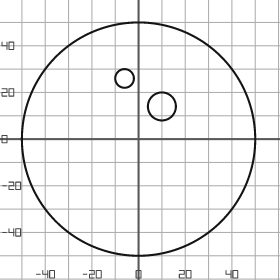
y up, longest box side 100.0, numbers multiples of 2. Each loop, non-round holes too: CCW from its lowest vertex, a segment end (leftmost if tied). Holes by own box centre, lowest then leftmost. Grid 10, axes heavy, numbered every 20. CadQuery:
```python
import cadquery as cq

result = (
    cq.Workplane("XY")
    .moveTo(0.0, 0.0)
    .circle(50.0)
    .moveTo(10.0, 14.0)
    .circle(6.0)
    .moveTo(-6.0, 26.0)
    .circle(4.0)
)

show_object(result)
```